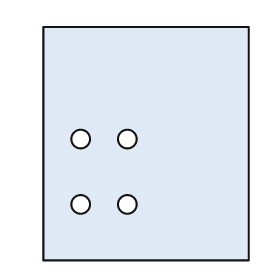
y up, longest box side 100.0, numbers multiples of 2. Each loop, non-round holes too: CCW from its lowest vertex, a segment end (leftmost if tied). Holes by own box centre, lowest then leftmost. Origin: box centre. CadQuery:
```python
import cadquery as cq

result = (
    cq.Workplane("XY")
    .moveTo(-44.0, -50.0)
    .lineTo(44.0, -50.0)
    .lineTo(44.0, 50.0)
    .lineTo(-44.0, 50.0)
    .close()
    .moveTo(-28.0, -26.0)
    .circle(4.0)
    .moveTo(-8.0, -26.0)
    .circle(4.0)
    .moveTo(-28.0, 2.0)
    .circle(4.0)
    .moveTo(-8.0, 2.0)
    .circle(4.0)
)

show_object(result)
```